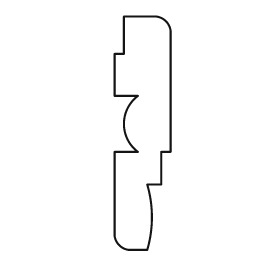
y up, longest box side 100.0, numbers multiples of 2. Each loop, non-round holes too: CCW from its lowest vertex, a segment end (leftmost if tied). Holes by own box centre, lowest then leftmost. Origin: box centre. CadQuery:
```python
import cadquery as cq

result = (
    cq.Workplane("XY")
    .moveTo(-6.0, -50.0)
    .lineTo(2.0, -50.0)
    .threePointArc((4.0, -36.0), (2.0, -22.0))
    .lineTo(8.0, -22.0)
    .lineTo(8.0, -8.0)
    .lineTo(12.0, -8.0)
    .lineTo(12.0, 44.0)
    .threePointArc((10.0, 48.0), (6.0, 50.0))
    .lineTo(-8.0, 50.0)
    .lineTo(-8.0, 34.0)
    .lineTo(-12.0, 34.0)
    .lineTo(-12.0, 16.0)
    .lineTo(-2.0, 16.0)
    .threePointArc((-8.0, 4.0), (-2.0, -8.0))
    .lineTo(-12.0, -8.0)
    .lineTo(-12.0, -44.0)
    .threePointArc((-10.0, -48.0), (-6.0, -50.0))
    .close()
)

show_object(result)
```